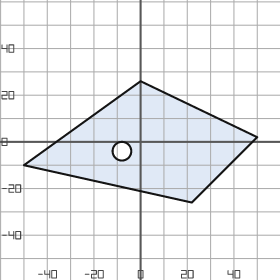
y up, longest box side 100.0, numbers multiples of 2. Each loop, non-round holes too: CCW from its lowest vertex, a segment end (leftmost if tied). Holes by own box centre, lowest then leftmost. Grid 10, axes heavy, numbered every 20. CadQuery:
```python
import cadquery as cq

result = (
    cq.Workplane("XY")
    .moveTo(22.0, -26.0)
    .lineTo(50.0, 2.0)
    .lineTo(0.0, 26.0)
    .lineTo(-50.0, -10.0)
    .close()
    .moveTo(-8.0, -4.0)
    .circle(4.0)
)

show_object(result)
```